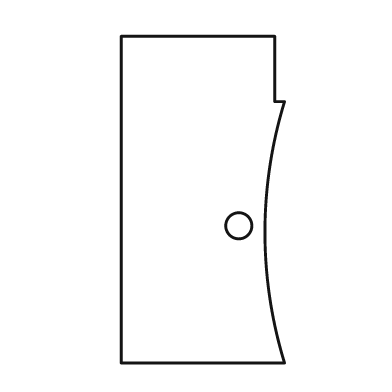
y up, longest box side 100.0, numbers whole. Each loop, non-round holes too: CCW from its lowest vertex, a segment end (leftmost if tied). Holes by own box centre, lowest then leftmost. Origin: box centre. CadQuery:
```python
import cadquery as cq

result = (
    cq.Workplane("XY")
    .moveTo(-25.0, -50.0)
    .lineTo(25.0, -50.0)
    .threePointArc((19.0, -10.0), (25.0, 30.0))
    .lineTo(22.0, 30.0)
    .lineTo(22.0, 50.0)
    .lineTo(-25.0, 50.0)
    .close()
    .moveTo(11.0, -8.0)
    .circle(4.0)
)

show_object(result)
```